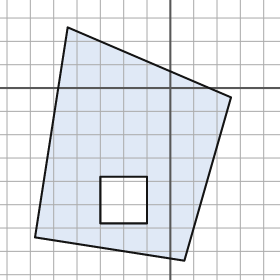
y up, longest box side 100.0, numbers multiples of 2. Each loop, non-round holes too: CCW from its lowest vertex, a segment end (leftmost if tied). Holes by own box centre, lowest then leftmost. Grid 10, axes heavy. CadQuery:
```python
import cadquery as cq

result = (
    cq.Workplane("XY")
    .moveTo(6.0, -74.0)
    .lineTo(26.0, -4.0)
    .lineTo(-44.0, 26.0)
    .lineTo(-58.0, -64.0)
    .close()
    .moveTo(-30.0, -58.0)
    .lineTo(-10.0, -58.0)
    .lineTo(-10.0, -38.0)
    .lineTo(-30.0, -38.0)
    .close()
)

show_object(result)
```